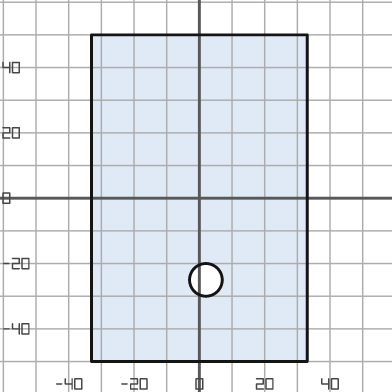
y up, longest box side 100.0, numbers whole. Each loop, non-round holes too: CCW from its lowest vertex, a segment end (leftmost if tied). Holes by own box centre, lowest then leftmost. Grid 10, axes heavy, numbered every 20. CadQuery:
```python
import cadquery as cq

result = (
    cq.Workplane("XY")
    .moveTo(-33.0, -50.0)
    .lineTo(33.0, -50.0)
    .lineTo(33.0, 50.0)
    .lineTo(-33.0, 50.0)
    .close()
    .moveTo(2.0, -25.0)
    .circle(5.0)
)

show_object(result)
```